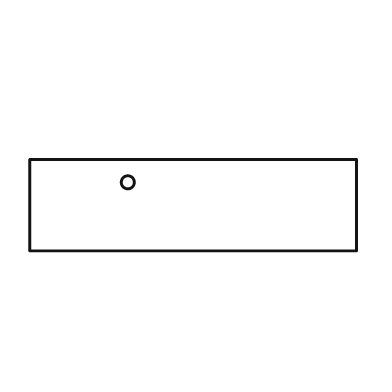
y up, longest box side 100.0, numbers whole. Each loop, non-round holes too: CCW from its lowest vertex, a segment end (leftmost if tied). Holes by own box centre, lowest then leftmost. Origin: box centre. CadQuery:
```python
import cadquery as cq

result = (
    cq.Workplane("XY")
    .moveTo(-50.0, -14.0)
    .lineTo(50.0, -14.0)
    .lineTo(50.0, 14.0)
    .lineTo(-50.0, 14.0)
    .close()
    .moveTo(-20.0, 7.0)
    .circle(2.0)
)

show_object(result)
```